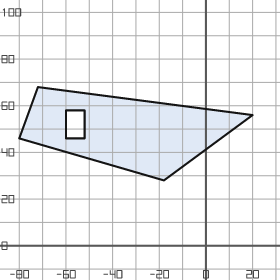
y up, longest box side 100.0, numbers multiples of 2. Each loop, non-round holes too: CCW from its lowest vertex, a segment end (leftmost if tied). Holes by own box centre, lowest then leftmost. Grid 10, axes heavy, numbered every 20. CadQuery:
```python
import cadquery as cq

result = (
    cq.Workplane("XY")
    .moveTo(-18.0, 28.0)
    .lineTo(20.0, 56.0)
    .lineTo(-72.0, 68.0)
    .lineTo(-80.0, 46.0)
    .close()
    .moveTo(-60.0, 46.0)
    .lineTo(-52.0, 46.0)
    .lineTo(-52.0, 58.0)
    .lineTo(-60.0, 58.0)
    .close()
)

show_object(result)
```